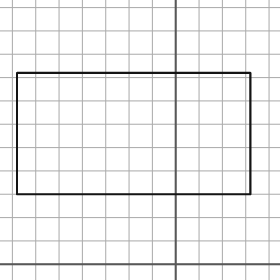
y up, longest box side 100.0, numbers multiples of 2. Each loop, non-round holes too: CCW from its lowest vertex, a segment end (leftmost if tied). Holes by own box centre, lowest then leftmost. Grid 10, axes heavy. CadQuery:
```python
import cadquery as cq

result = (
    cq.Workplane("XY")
    .moveTo(-68.0, 30.0)
    .lineTo(32.0, 30.0)
    .lineTo(32.0, 82.0)
    .lineTo(-68.0, 82.0)
    .close()
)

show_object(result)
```